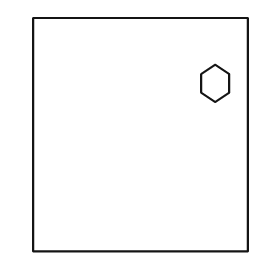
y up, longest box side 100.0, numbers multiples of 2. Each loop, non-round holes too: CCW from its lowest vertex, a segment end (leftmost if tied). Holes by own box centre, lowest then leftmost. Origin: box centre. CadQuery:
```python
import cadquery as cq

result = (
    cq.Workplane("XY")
    .moveTo(-46.0, -50.0)
    .lineTo(46.0, -50.0)
    .lineTo(46.0, 50.0)
    .lineTo(-46.0, 50.0)
    .close()
    .moveTo(32.0, 14.0)
    .lineTo(38.0, 18.0)
    .lineTo(38.0, 26.0)
    .lineTo(32.0, 30.0)
    .lineTo(26.0, 26.0)
    .lineTo(26.0, 18.0)
    .close()
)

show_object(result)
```